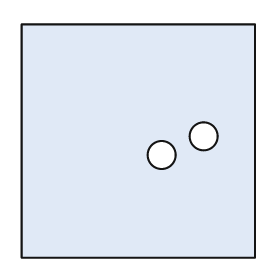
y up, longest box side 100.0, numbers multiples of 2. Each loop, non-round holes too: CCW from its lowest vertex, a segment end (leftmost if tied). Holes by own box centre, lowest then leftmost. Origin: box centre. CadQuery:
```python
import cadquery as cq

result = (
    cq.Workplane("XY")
    .moveTo(-50.0, -50.0)
    .lineTo(50.0, -50.0)
    .lineTo(50.0, 50.0)
    .lineTo(-50.0, 50.0)
    .close()
    .moveTo(10.0, -6.0)
    .circle(6.0)
    .moveTo(28.0, 2.0)
    .circle(6.0)
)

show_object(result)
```